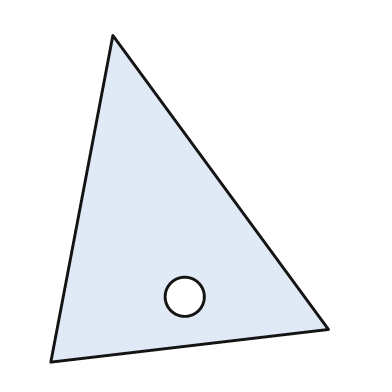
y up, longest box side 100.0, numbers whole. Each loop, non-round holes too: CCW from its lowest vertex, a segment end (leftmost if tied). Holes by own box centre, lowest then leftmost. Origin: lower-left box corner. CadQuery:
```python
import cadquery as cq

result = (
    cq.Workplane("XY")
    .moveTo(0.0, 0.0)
    .lineTo(85.0, 10.0)
    .lineTo(19.0, 100.0)
    .close()
    .moveTo(41.0, 20.0)
    .circle(6.0)
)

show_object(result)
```